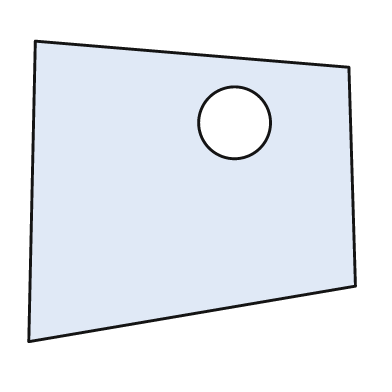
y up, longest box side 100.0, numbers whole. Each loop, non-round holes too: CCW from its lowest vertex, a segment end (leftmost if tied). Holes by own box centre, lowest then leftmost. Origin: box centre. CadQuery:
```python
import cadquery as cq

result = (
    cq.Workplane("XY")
    .moveTo(-50.0, -46.0)
    .lineTo(50.0, -29.0)
    .lineTo(48.0, 38.0)
    .lineTo(-48.0, 46.0)
    .close()
    .moveTo(13.0, 21.0)
    .circle(11.0)
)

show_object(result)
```